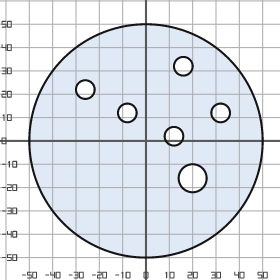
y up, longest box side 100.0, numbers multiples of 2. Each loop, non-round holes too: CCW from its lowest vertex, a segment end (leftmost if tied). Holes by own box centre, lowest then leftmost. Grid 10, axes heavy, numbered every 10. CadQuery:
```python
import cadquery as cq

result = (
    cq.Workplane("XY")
    .moveTo(0.0, 0.0)
    .circle(50.0)
    .moveTo(20.0, -16.0)
    .circle(6.0)
    .moveTo(12.0, 2.0)
    .circle(4.0)
    .moveTo(-8.0, 12.0)
    .circle(4.0)
    .moveTo(32.0, 12.0)
    .circle(4.0)
    .moveTo(-26.0, 22.0)
    .circle(4.0)
    .moveTo(16.0, 32.0)
    .circle(4.0)
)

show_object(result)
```